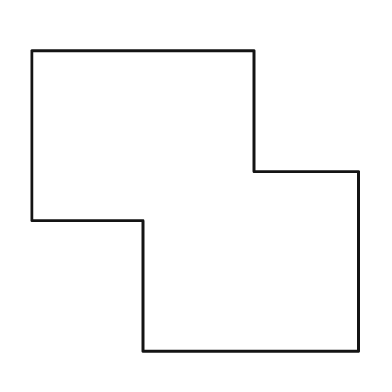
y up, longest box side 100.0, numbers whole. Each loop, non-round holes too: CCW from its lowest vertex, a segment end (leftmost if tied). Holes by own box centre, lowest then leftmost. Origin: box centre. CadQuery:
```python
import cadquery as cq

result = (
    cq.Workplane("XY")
    .moveTo(-16.0, -46.0)
    .lineTo(50.0, -46.0)
    .lineTo(50.0, 9.0)
    .lineTo(18.0, 9.0)
    .lineTo(18.0, 46.0)
    .lineTo(-50.0, 46.0)
    .lineTo(-50.0, -6.0)
    .lineTo(-16.0, -6.0)
    .close()
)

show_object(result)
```